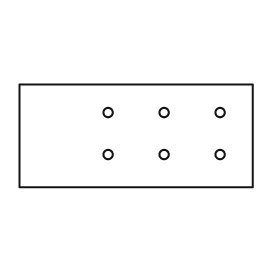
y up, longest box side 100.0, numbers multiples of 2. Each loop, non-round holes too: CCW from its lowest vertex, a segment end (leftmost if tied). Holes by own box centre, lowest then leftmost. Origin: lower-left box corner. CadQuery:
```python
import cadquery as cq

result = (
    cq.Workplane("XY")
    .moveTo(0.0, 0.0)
    .lineTo(100.0, 0.0)
    .lineTo(100.0, 44.0)
    .lineTo(0.0, 44.0)
    .close()
    .moveTo(38.0, 14.0)
    .circle(2.0)
    .moveTo(62.0, 14.0)
    .circle(2.0)
    .moveTo(86.0, 14.0)
    .circle(2.0)
    .moveTo(38.0, 32.0)
    .circle(2.0)
    .moveTo(62.0, 32.0)
    .circle(2.0)
    .moveTo(86.0, 32.0)
    .circle(2.0)
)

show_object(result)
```